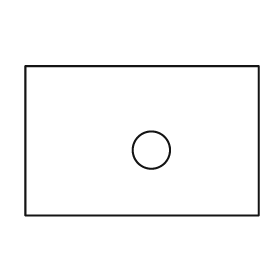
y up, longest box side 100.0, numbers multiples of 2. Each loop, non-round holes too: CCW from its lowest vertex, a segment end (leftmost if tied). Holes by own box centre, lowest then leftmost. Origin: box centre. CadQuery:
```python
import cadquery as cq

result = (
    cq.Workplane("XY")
    .moveTo(-50.0, -32.0)
    .lineTo(50.0, -32.0)
    .lineTo(50.0, 32.0)
    .lineTo(-50.0, 32.0)
    .close()
    .moveTo(4.0, -4.0)
    .circle(8.0)
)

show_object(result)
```